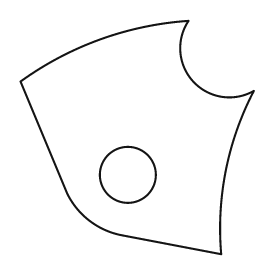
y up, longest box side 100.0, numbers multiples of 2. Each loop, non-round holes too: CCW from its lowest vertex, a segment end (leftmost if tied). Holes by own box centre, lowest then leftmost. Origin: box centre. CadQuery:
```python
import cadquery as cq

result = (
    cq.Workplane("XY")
    .moveTo(36.0, -50.0)
    .threePointArc((38.0, -14.0), (50.0, 20.0))
    .threePointArc((24.0, 24.0), (22.0, 50.0))
    .threePointArc((-16.0, 42.0), (-50.0, 24.0))
    .lineTo(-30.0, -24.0)
    .threePointArc((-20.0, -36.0), (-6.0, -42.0))
    .close()
    .moveTo(-4.0, -16.0)
    .circle(12.0)
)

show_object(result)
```